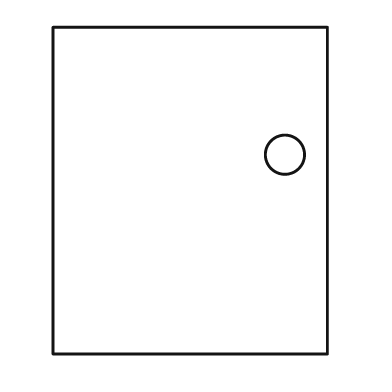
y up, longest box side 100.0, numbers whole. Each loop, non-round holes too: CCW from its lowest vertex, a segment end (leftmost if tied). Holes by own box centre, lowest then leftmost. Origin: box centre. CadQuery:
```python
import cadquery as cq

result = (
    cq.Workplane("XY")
    .moveTo(-42.0, -50.0)
    .lineTo(42.0, -50.0)
    .lineTo(42.0, 50.0)
    .lineTo(-42.0, 50.0)
    .close()
    .moveTo(29.0, 11.0)
    .circle(6.0)
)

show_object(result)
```